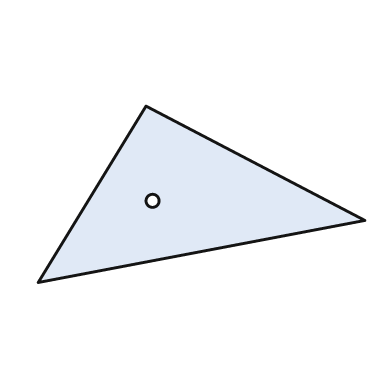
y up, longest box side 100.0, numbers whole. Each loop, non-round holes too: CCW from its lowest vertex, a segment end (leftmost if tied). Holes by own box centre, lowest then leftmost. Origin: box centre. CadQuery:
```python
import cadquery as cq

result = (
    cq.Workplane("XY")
    .moveTo(-50.0, -27.0)
    .lineTo(50.0, -8.0)
    .lineTo(-17.0, 27.0)
    .close()
    .moveTo(-15.0, -2.0)
    .circle(2.0)
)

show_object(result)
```